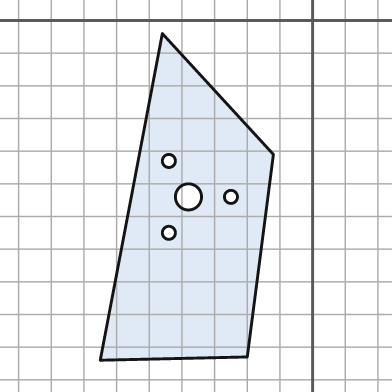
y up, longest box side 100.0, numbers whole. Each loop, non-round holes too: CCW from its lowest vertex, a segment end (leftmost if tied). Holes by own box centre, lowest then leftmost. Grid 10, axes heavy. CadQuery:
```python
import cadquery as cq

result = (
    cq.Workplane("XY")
    .moveTo(-65.0, -104.0)
    .lineTo(-20.0, -103.0)
    .lineTo(-12.0, -41.0)
    .lineTo(-46.0, -4.0)
    .close()
    .moveTo(-44.0, -65.0)
    .circle(2.0)
    .moveTo(-38.0, -54.0)
    .circle(4.0)
    .moveTo(-25.0, -54.0)
    .circle(2.0)
    .moveTo(-44.0, -43.0)
    .circle(2.0)
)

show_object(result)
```